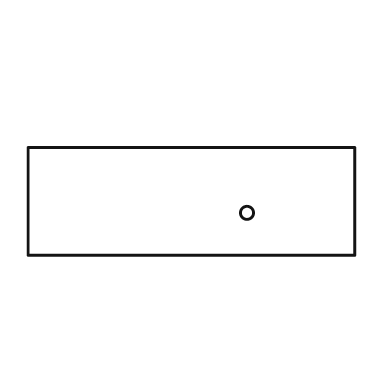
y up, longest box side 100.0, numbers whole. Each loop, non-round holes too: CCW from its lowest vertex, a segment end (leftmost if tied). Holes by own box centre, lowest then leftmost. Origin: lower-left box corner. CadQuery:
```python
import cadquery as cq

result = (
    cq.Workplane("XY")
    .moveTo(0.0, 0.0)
    .lineTo(100.0, 0.0)
    .lineTo(100.0, 33.0)
    .lineTo(0.0, 33.0)
    .close()
    .moveTo(67.0, 13.0)
    .circle(2.0)
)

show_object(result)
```